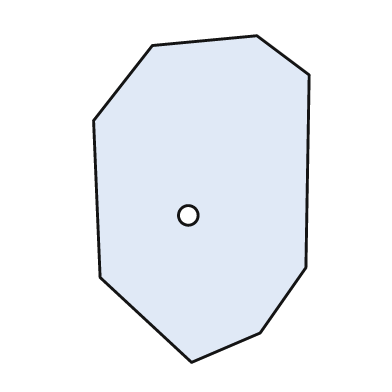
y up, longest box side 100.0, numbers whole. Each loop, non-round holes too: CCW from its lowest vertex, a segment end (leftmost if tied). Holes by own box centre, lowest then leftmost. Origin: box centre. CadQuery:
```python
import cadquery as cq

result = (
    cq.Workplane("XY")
    .moveTo(-3.0, -50.0)
    .lineTo(18.0, -41.0)
    .lineTo(32.0, -21.0)
    .lineTo(33.0, 38.0)
    .lineTo(17.0, 50.0)
    .lineTo(-15.0, 47.0)
    .lineTo(-33.0, 24.0)
    .lineTo(-31.0, -24.0)
    .close()
    .moveTo(-4.0, -5.0)
    .circle(3.0)
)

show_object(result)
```